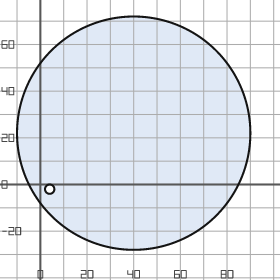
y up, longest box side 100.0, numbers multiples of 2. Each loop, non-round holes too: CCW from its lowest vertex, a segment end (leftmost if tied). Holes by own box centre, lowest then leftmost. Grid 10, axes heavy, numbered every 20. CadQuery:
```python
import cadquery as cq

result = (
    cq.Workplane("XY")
    .moveTo(40.0, 22.0)
    .circle(50.0)
    .moveTo(4.0, -2.0)
    .circle(2.0)
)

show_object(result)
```